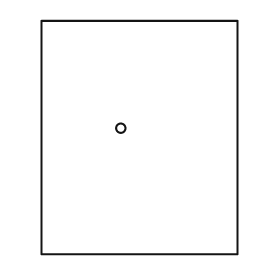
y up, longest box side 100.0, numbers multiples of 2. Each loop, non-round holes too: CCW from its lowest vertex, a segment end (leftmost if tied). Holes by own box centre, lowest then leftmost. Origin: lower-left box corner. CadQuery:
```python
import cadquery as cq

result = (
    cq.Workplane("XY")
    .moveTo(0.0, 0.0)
    .lineTo(84.0, 0.0)
    .lineTo(84.0, 100.0)
    .lineTo(0.0, 100.0)
    .close()
    .moveTo(34.0, 54.0)
    .circle(2.0)
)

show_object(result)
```